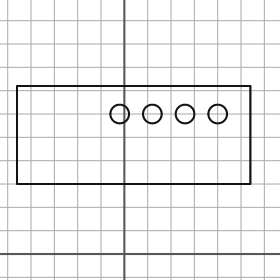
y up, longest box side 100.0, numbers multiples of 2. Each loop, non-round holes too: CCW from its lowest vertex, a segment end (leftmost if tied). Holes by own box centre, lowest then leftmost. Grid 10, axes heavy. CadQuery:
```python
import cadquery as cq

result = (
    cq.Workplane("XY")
    .moveTo(-46.0, 30.0)
    .lineTo(54.0, 30.0)
    .lineTo(54.0, 72.0)
    .lineTo(-46.0, 72.0)
    .close()
    .moveTo(-2.0, 60.0)
    .circle(4.0)
    .moveTo(12.0, 60.0)
    .circle(4.0)
    .moveTo(26.0, 60.0)
    .circle(4.0)
    .moveTo(40.0, 60.0)
    .circle(4.0)
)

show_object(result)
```